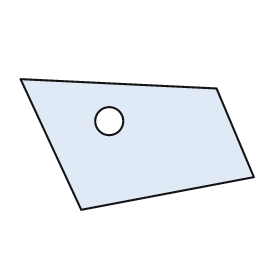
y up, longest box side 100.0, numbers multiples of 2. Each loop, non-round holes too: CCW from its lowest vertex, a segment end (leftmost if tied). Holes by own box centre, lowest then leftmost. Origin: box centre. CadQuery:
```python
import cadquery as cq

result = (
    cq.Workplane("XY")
    .moveTo(-24.0, -28.0)
    .lineTo(50.0, -14.0)
    .lineTo(34.0, 24.0)
    .lineTo(-50.0, 28.0)
    .close()
    .moveTo(-12.0, 10.0)
    .circle(6.0)
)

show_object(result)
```